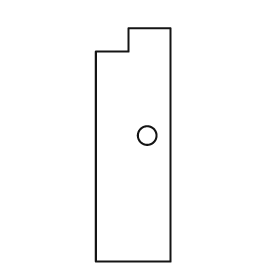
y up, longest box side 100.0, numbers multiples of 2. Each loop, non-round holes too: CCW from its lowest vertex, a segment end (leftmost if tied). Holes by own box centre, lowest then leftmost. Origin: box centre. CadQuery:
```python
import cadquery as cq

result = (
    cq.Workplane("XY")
    .moveTo(-16.0, -50.0)
    .lineTo(16.0, -50.0)
    .lineTo(16.0, 50.0)
    .lineTo(-2.0, 50.0)
    .lineTo(-2.0, 40.0)
    .lineTo(-16.0, 40.0)
    .close()
    .moveTo(6.0, 4.0)
    .circle(4.0)
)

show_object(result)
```